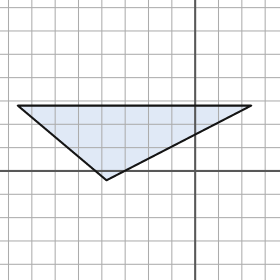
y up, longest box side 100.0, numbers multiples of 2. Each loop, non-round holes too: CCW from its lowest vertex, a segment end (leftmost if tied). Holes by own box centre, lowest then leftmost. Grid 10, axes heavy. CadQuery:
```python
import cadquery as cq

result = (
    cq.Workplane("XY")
    .moveTo(-38.0, -4.0)
    .lineTo(24.0, 28.0)
    .lineTo(-76.0, 28.0)
    .close()
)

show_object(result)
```